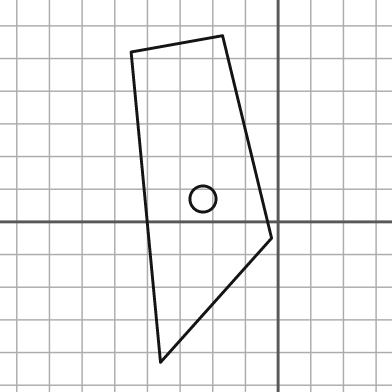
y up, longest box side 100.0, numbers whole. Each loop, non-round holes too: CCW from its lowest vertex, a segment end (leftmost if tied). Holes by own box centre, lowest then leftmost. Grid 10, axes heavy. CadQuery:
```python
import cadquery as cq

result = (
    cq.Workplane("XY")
    .moveTo(-36.0, -43.0)
    .lineTo(-2.0, -5.0)
    .lineTo(-17.0, 57.0)
    .lineTo(-45.0, 52.0)
    .close()
    .moveTo(-23.0, 7.0)
    .circle(4.0)
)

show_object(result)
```